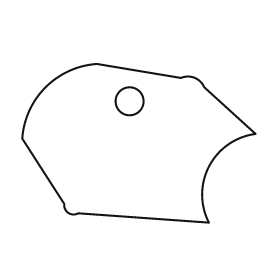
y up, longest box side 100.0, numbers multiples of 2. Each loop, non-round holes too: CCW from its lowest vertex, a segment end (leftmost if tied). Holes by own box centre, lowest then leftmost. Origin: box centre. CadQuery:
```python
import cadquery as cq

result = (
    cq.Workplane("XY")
    .moveTo(30.0, -34.0)
    .threePointArc((30.0, -10.0), (50.0, 4.0))
    .lineTo(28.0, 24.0)
    .threePointArc((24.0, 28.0), (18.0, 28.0))
    .lineTo(-18.0, 34.0)
    .threePointArc((-40.0, 24.0), (-50.0, 2.0))
    .lineTo(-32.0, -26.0)
    .threePointArc((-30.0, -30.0), (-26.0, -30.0))
    .close()
    .moveTo(-4.0, 18.0)
    .circle(6.0)
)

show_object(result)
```